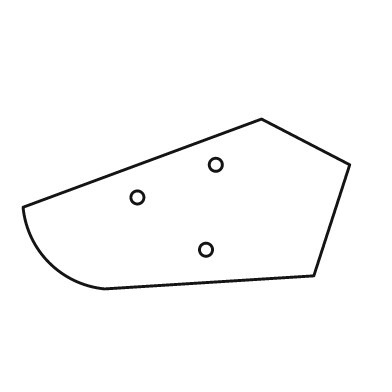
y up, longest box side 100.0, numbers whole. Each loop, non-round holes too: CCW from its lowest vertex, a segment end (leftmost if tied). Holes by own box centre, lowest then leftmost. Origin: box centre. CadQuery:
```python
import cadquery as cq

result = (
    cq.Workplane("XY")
    .moveTo(-25.0, -26.0)
    .lineTo(39.0, -22.0)
    .lineTo(50.0, 12.0)
    .lineTo(23.0, 26.0)
    .lineTo(-50.0, -1.0)
    .threePointArc((-42.0, -18.0), (-25.0, -26.0))
    .close()
    .moveTo(6.0, -14.0)
    .circle(2.0)
    .moveTo(-15.0, 2.0)
    .circle(2.0)
    .moveTo(9.0, 12.0)
    .circle(2.0)
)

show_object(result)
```